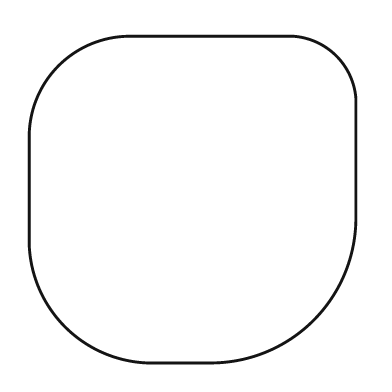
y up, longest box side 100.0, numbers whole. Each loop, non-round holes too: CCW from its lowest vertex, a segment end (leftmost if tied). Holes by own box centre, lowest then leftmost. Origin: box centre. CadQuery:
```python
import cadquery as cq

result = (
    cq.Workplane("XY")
    .moveTo(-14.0, -50.0)
    .lineTo(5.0, -50.0)
    .threePointArc((37.0, -37.0), (50.0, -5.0))
    .lineTo(50.0, 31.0)
    .threePointArc((44.0, 44.0), (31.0, 50.0))
    .lineTo(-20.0, 50.0)
    .threePointArc((-41.0, 41.0), (-50.0, 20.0))
    .lineTo(-50.0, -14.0)
    .threePointArc((-39.0, -39.0), (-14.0, -50.0))
    .close()
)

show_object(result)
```